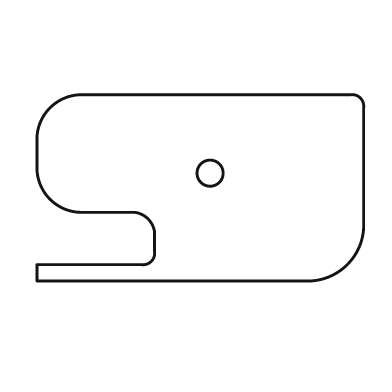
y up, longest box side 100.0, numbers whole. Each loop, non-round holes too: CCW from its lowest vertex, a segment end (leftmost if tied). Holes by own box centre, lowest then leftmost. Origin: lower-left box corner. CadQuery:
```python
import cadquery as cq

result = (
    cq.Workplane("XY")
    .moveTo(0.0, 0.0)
    .lineTo(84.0, 0.0)
    .threePointArc((95.0, 5.0), (100.0, 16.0))
    .lineTo(100.0, 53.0)
    .threePointArc((99.0, 56.0), (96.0, 57.0))
    .lineTo(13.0, 57.0)
    .threePointArc((4.0, 53.0), (0.0, 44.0))
    .lineTo(0.0, 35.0)
    .threePointArc((4.0, 25.0), (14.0, 21.0))
    .lineTo(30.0, 21.0)
    .threePointArc((34.0, 19.0), (36.0, 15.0))
    .lineTo(36.0, 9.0)
    .threePointArc((35.0, 6.0), (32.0, 5.0))
    .lineTo(0.0, 5.0)
    .close()
    .moveTo(53.0, 33.0)
    .circle(4.0)
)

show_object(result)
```